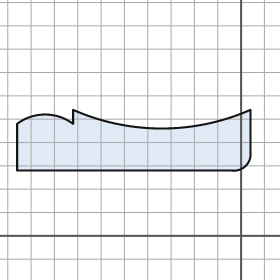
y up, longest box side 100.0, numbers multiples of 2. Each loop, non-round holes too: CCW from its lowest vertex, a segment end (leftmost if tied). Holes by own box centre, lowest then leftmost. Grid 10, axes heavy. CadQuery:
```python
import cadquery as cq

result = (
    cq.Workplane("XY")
    .moveTo(-96.0, 28.0)
    .lineTo(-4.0, 28.0)
    .threePointArc((2.0, 30.0), (4.0, 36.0))
    .lineTo(4.0, 54.0)
    .threePointArc((-34.0, 46.0), (-72.0, 54.0))
    .lineTo(-72.0, 48.0)
    .threePointArc((-84.0, 52.0), (-96.0, 48.0))
    .close()
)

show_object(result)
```